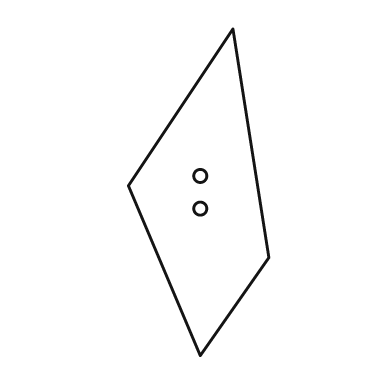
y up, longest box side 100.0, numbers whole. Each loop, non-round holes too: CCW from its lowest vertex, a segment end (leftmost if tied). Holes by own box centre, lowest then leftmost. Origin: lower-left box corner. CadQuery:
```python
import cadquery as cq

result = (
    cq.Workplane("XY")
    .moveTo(22.0, 0.0)
    .lineTo(43.0, 30.0)
    .lineTo(32.0, 100.0)
    .lineTo(0.0, 52.0)
    .close()
    .moveTo(22.0, 45.0)
    .circle(2.0)
    .moveTo(22.0, 55.0)
    .circle(2.0)
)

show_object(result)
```